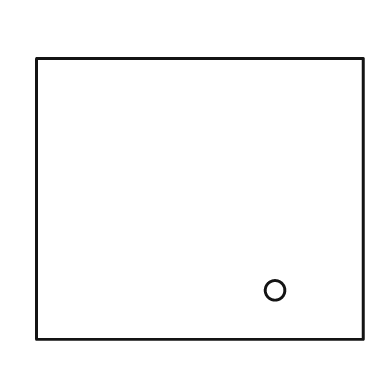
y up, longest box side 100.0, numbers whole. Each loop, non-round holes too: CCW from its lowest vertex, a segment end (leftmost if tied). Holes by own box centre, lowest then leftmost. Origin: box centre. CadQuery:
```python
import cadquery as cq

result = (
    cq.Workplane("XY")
    .moveTo(-50.0, -43.0)
    .lineTo(50.0, -43.0)
    .lineTo(50.0, 43.0)
    .lineTo(-50.0, 43.0)
    .close()
    .moveTo(23.0, -28.0)
    .circle(3.0)
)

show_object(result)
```